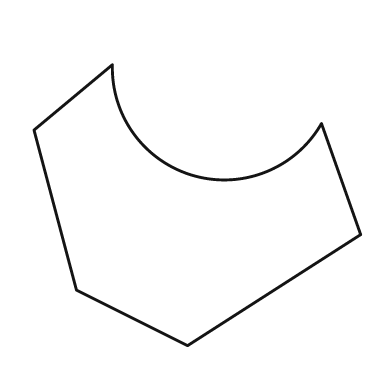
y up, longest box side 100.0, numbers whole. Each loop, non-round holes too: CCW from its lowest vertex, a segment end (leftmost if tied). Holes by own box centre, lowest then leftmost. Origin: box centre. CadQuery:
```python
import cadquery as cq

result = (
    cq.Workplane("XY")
    .moveTo(-3.0, -43.0)
    .lineTo(50.0, -9.0)
    .lineTo(38.0, 25.0)
    .threePointArc((-1.0, 9.0), (-26.0, 43.0))
    .lineTo(-50.0, 23.0)
    .lineTo(-37.0, -26.0)
    .close()
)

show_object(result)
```